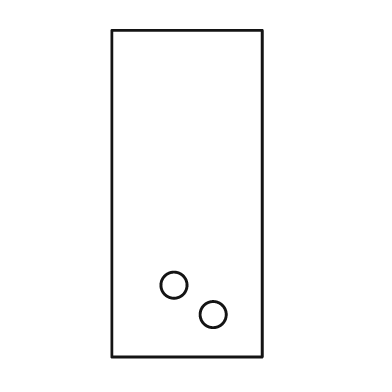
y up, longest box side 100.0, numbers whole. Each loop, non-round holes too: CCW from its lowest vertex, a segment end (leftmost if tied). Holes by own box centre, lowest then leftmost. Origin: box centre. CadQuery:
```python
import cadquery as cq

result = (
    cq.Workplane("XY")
    .moveTo(-23.0, -50.0)
    .lineTo(23.0, -50.0)
    .lineTo(23.0, 50.0)
    .lineTo(-23.0, 50.0)
    .close()
    .moveTo(8.0, -37.0)
    .circle(4.0)
    .moveTo(-4.0, -28.0)
    .circle(4.0)
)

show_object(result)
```